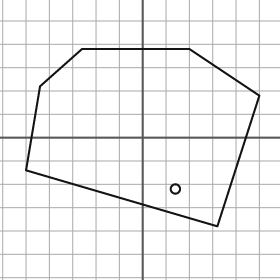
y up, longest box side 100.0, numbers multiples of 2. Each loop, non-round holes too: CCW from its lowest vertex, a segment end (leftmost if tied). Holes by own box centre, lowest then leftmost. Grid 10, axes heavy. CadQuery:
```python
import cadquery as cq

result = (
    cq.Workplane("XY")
    .moveTo(32.0, -38.0)
    .lineTo(50.0, 18.0)
    .lineTo(20.0, 38.0)
    .lineTo(-26.0, 38.0)
    .lineTo(-44.0, 22.0)
    .lineTo(-50.0, -14.0)
    .close()
    .moveTo(14.0, -22.0)
    .circle(2.0)
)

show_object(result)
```